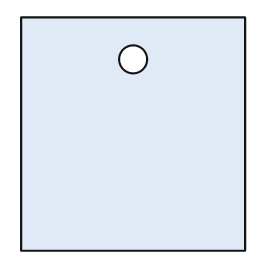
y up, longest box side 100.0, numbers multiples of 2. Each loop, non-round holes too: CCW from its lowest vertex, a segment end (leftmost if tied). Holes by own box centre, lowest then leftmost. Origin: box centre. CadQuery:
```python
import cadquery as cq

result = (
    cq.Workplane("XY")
    .moveTo(-48.0, -50.0)
    .lineTo(48.0, -50.0)
    .lineTo(48.0, 50.0)
    .lineTo(-48.0, 50.0)
    .close()
    .moveTo(0.0, 32.0)
    .circle(6.0)
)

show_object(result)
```